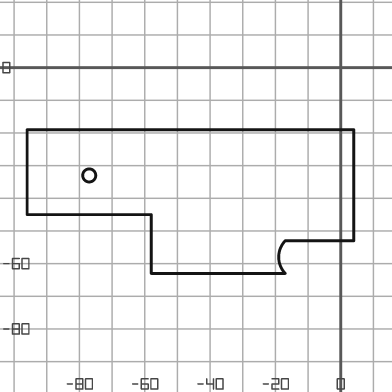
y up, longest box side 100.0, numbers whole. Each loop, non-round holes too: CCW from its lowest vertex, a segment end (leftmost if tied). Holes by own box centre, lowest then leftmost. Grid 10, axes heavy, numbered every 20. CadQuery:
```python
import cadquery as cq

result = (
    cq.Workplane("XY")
    .moveTo(-58.0, -63.0)
    .lineTo(-17.0, -63.0)
    .threePointArc((-19.0, -58.0), (-17.0, -53.0))
    .lineTo(4.0, -53.0)
    .lineTo(4.0, -19.0)
    .lineTo(-96.0, -19.0)
    .lineTo(-96.0, -45.0)
    .lineTo(-58.0, -45.0)
    .close()
    .moveTo(-77.0, -33.0)
    .circle(2.0)
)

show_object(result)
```